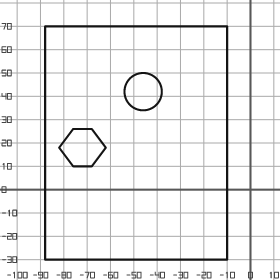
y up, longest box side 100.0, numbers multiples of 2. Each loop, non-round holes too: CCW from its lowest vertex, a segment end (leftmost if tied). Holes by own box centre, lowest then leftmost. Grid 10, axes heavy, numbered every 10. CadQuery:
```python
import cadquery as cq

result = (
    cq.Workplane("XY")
    .moveTo(-88.0, -30.0)
    .lineTo(-10.0, -30.0)
    .lineTo(-10.0, 70.0)
    .lineTo(-88.0, 70.0)
    .close()
    .moveTo(-76.0, 10.0)
    .lineTo(-68.0, 10.0)
    .lineTo(-62.0, 18.0)
    .lineTo(-68.0, 26.0)
    .lineTo(-76.0, 26.0)
    .lineTo(-82.0, 18.0)
    .close()
    .moveTo(-46.0, 42.0)
    .circle(8.0)
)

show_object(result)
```